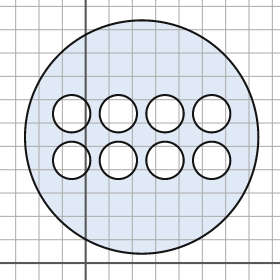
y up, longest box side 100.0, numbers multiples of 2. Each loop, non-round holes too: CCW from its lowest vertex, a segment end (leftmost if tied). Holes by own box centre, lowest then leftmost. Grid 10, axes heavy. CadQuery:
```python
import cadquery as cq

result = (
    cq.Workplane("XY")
    .moveTo(24.0, 54.0)
    .circle(50.0)
    .moveTo(-6.0, 44.0)
    .circle(8.0)
    .moveTo(14.0, 44.0)
    .circle(8.0)
    .moveTo(34.0, 44.0)
    .circle(8.0)
    .moveTo(54.0, 44.0)
    .circle(8.0)
    .moveTo(-6.0, 64.0)
    .circle(8.0)
    .moveTo(14.0, 64.0)
    .circle(8.0)
    .moveTo(34.0, 64.0)
    .circle(8.0)
    .moveTo(54.0, 64.0)
    .circle(8.0)
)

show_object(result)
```